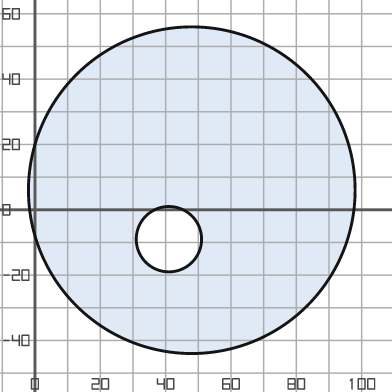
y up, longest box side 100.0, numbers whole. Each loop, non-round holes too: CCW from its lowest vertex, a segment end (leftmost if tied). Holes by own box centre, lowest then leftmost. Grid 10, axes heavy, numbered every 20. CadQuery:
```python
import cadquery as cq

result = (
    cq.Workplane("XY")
    .moveTo(48.0, 6.0)
    .circle(50.0)
    .moveTo(41.0, -9.0)
    .circle(10.0)
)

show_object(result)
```